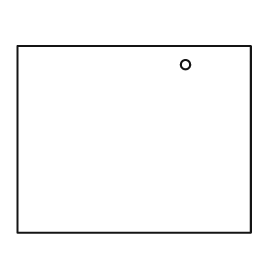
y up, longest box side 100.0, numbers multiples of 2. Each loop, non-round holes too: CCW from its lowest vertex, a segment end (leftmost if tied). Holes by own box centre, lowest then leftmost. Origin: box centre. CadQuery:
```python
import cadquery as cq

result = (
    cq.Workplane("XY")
    .moveTo(-50.0, -40.0)
    .lineTo(50.0, -40.0)
    .lineTo(50.0, 40.0)
    .lineTo(-50.0, 40.0)
    .close()
    .moveTo(22.0, 32.0)
    .circle(2.0)
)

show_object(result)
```